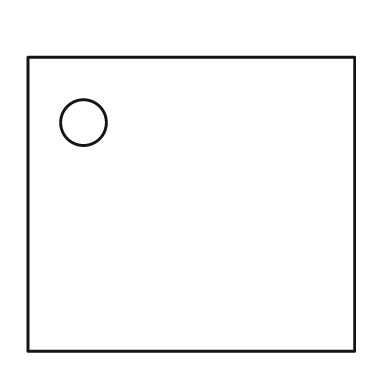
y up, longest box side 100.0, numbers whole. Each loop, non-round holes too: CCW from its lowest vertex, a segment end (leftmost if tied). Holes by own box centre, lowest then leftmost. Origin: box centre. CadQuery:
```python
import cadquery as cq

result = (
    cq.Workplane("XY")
    .moveTo(-50.0, -45.0)
    .lineTo(50.0, -45.0)
    .lineTo(50.0, 45.0)
    .lineTo(-50.0, 45.0)
    .close()
    .moveTo(-33.0, 25.0)
    .circle(7.0)
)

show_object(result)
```